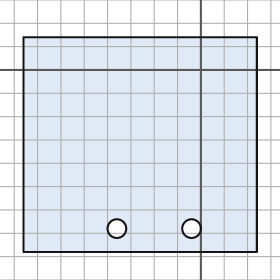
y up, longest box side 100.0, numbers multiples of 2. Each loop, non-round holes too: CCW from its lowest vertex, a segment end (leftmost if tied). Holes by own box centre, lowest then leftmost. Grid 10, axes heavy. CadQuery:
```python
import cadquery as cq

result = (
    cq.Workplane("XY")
    .moveTo(-76.0, -78.0)
    .lineTo(24.0, -78.0)
    .lineTo(24.0, 14.0)
    .lineTo(-76.0, 14.0)
    .close()
    .moveTo(-36.0, -68.0)
    .circle(4.0)
    .moveTo(-4.0, -68.0)
    .circle(4.0)
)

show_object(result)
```